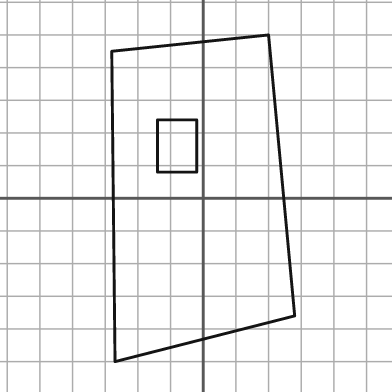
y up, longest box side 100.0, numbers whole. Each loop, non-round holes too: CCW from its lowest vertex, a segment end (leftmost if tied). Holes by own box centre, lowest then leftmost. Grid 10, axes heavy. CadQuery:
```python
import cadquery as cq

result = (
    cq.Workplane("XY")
    .moveTo(-27.0, -50.0)
    .lineTo(28.0, -36.0)
    .lineTo(20.0, 50.0)
    .lineTo(-28.0, 45.0)
    .close()
    .moveTo(-14.0, 8.0)
    .lineTo(-2.0, 8.0)
    .lineTo(-2.0, 24.0)
    .lineTo(-14.0, 24.0)
    .close()
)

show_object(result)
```